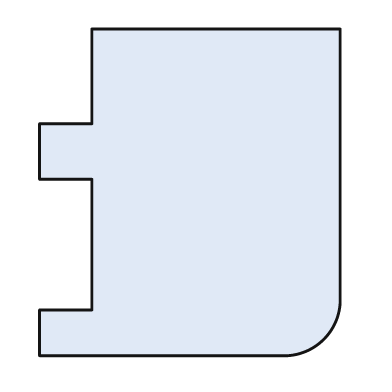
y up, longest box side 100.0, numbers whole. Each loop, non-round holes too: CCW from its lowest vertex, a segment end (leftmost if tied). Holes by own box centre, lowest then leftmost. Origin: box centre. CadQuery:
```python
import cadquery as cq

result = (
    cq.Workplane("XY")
    .moveTo(-46.0, -50.0)
    .lineTo(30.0, -50.0)
    .threePointArc((41.0, -45.0), (46.0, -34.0))
    .lineTo(46.0, 50.0)
    .lineTo(-30.0, 50.0)
    .lineTo(-30.0, 21.0)
    .lineTo(-46.0, 21.0)
    .lineTo(-46.0, 4.0)
    .lineTo(-30.0, 4.0)
    .lineTo(-30.0, -36.0)
    .lineTo(-46.0, -36.0)
    .close()
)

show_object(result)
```